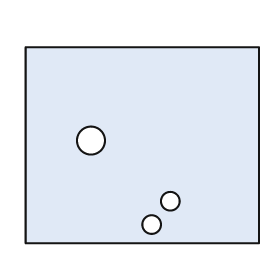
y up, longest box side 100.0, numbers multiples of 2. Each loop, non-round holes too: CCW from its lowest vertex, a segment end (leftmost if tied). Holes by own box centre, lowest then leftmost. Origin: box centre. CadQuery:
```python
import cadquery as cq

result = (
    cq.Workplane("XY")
    .moveTo(-50.0, -42.0)
    .lineTo(50.0, -42.0)
    .lineTo(50.0, 42.0)
    .lineTo(-50.0, 42.0)
    .close()
    .moveTo(4.0, -34.0)
    .circle(4.0)
    .moveTo(12.0, -24.0)
    .circle(4.0)
    .moveTo(-22.0, 2.0)
    .circle(6.0)
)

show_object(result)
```